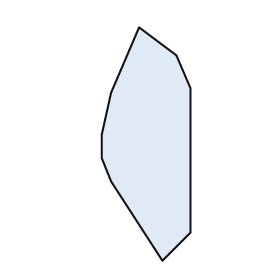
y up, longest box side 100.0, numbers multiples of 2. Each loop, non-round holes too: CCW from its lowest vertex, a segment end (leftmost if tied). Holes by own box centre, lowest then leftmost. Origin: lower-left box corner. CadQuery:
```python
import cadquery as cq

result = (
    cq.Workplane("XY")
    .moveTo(26.0, 0.0)
    .lineTo(38.0, 12.0)
    .lineTo(38.0, 74.0)
    .lineTo(32.0, 88.0)
    .lineTo(16.0, 100.0)
    .lineTo(4.0, 72.0)
    .lineTo(0.0, 54.0)
    .lineTo(0.0, 44.0)
    .lineTo(4.0, 34.0)
    .close()
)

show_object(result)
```